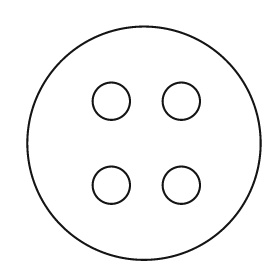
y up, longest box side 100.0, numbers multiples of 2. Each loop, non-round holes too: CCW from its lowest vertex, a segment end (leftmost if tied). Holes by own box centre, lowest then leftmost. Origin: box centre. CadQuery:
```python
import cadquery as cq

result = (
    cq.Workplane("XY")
    .moveTo(0.0, 0.0)
    .circle(50.0)
    .moveTo(-14.0, -18.0)
    .circle(8.0)
    .moveTo(16.0, -18.0)
    .circle(8.0)
    .moveTo(-14.0, 18.0)
    .circle(8.0)
    .moveTo(16.0, 18.0)
    .circle(8.0)
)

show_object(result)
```